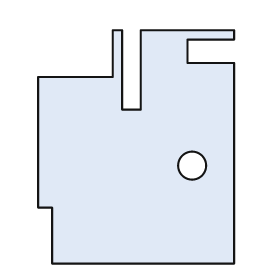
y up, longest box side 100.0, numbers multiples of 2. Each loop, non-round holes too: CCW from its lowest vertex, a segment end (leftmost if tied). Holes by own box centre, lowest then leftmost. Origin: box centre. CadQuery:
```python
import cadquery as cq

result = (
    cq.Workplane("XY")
    .moveTo(-36.0, -50.0)
    .lineTo(42.0, -50.0)
    .lineTo(42.0, 36.0)
    .lineTo(22.0, 36.0)
    .lineTo(22.0, 46.0)
    .lineTo(42.0, 46.0)
    .lineTo(42.0, 50.0)
    .lineTo(2.0, 50.0)
    .lineTo(2.0, 16.0)
    .lineTo(-6.0, 16.0)
    .lineTo(-6.0, 50.0)
    .lineTo(-10.0, 50.0)
    .lineTo(-10.0, 30.0)
    .lineTo(-42.0, 30.0)
    .lineTo(-42.0, -26.0)
    .lineTo(-36.0, -26.0)
    .close()
    .moveTo(24.0, -8.0)
    .circle(6.0)
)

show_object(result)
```